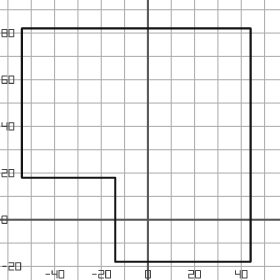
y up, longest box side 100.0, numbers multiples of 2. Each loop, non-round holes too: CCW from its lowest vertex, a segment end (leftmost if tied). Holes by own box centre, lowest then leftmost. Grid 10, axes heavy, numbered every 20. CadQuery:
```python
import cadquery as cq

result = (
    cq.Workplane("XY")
    .moveTo(-14.0, -18.0)
    .lineTo(44.0, -18.0)
    .lineTo(44.0, 82.0)
    .lineTo(-54.0, 82.0)
    .lineTo(-54.0, 18.0)
    .lineTo(-14.0, 18.0)
    .close()
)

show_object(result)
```